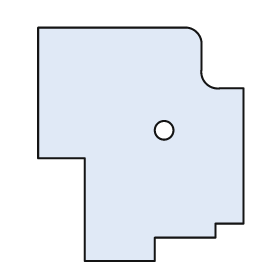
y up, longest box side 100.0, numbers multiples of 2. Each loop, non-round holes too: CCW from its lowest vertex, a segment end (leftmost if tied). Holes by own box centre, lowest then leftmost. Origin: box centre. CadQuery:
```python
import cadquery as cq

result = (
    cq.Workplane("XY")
    .moveTo(-24.0, -50.0)
    .lineTo(6.0, -50.0)
    .lineTo(6.0, -40.0)
    .lineTo(32.0, -40.0)
    .lineTo(32.0, -34.0)
    .lineTo(44.0, -34.0)
    .lineTo(44.0, 24.0)
    .lineTo(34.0, 24.0)
    .threePointArc((28.0, 26.0), (26.0, 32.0))
    .lineTo(26.0, 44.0)
    .threePointArc((24.0, 48.0), (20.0, 50.0))
    .lineTo(-44.0, 50.0)
    .lineTo(-44.0, -6.0)
    .lineTo(-24.0, -6.0)
    .close()
    .moveTo(10.0, 6.0)
    .circle(4.0)
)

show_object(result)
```